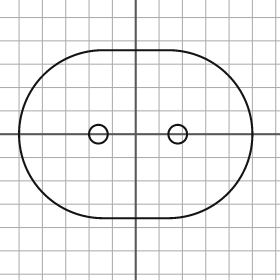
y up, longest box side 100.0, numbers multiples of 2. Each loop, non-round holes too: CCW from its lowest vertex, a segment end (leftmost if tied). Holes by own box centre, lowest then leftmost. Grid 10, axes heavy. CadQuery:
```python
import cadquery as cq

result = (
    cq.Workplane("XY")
    .moveTo(-14.0, -36.0)
    .lineTo(14.0, -36.0)
    .threePointArc((50.0, 0.0), (14.0, 36.0))
    .lineTo(-14.0, 36.0)
    .threePointArc((-50.0, 0.0), (-14.0, -36.0))
    .close()
    .moveTo(-16.0, 0.0)
    .circle(4.0)
    .moveTo(18.0, 0.0)
    .circle(4.0)
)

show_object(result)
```